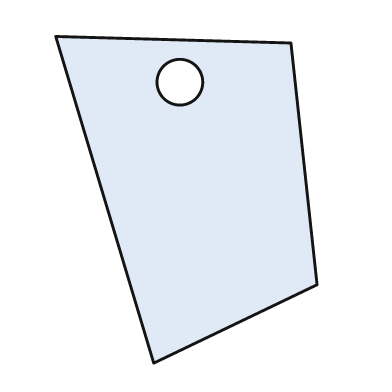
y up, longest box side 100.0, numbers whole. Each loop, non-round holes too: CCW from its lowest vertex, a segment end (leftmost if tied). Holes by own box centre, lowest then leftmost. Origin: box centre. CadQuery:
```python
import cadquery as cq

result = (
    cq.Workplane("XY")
    .moveTo(-10.0, -50.0)
    .lineTo(40.0, -26.0)
    .lineTo(32.0, 48.0)
    .lineTo(-40.0, 50.0)
    .close()
    .moveTo(-2.0, 36.0)
    .circle(7.0)
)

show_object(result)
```